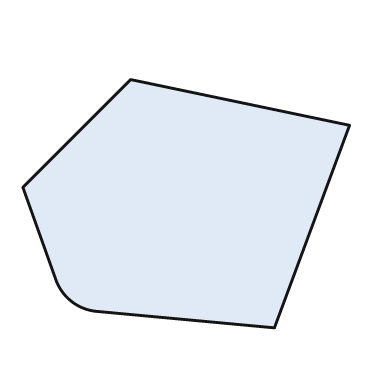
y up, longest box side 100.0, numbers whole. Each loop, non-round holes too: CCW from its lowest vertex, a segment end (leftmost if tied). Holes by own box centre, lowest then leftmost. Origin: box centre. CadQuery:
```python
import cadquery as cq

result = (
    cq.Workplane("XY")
    .moveTo(27.0, -38.0)
    .lineTo(50.0, 24.0)
    .lineTo(-17.0, 38.0)
    .lineTo(-50.0, 5.0)
    .lineTo(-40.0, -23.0)
    .threePointArc((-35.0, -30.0), (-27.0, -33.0))
    .close()
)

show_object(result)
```